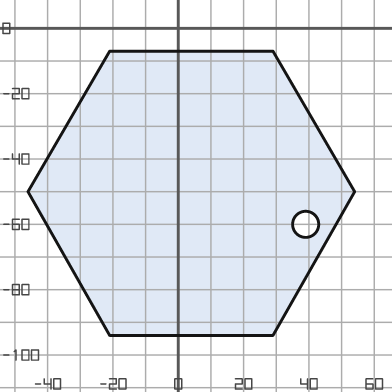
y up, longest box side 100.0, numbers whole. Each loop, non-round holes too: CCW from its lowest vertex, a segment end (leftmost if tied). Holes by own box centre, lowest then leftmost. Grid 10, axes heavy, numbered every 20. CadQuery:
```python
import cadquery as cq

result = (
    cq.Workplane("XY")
    .moveTo(-21.0, -94.0)
    .lineTo(29.0, -94.0)
    .lineTo(54.0, -50.0)
    .lineTo(29.0, -7.0)
    .lineTo(-21.0, -7.0)
    .lineTo(-46.0, -50.0)
    .close()
    .moveTo(39.0, -60.0)
    .circle(4.0)
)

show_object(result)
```